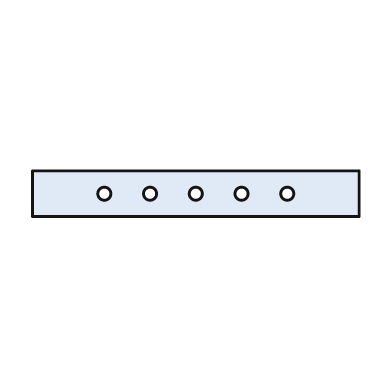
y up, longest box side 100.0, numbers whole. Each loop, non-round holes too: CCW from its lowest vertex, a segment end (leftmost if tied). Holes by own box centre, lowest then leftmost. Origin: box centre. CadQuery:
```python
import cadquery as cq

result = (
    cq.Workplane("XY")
    .moveTo(-50.0, -7.0)
    .lineTo(50.0, -7.0)
    .lineTo(50.0, 7.0)
    .lineTo(-50.0, 7.0)
    .close()
    .moveTo(-28.0, 0.0)
    .circle(2.0)
    .moveTo(-14.0, 0.0)
    .circle(2.0)
    .moveTo(0.0, 0.0)
    .circle(2.0)
    .moveTo(14.0, 0.0)
    .circle(2.0)
    .moveTo(28.0, 0.0)
    .circle(2.0)
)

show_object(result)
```